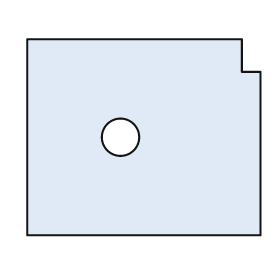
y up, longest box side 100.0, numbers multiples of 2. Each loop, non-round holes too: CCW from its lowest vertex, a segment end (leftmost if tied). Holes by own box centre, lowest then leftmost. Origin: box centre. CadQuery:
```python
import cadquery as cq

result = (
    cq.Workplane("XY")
    .moveTo(-50.0, -42.0)
    .lineTo(50.0, -42.0)
    .lineTo(50.0, 28.0)
    .lineTo(42.0, 28.0)
    .lineTo(42.0, 42.0)
    .lineTo(-50.0, 42.0)
    .close()
    .moveTo(-10.0, 0.0)
    .circle(8.0)
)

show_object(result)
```